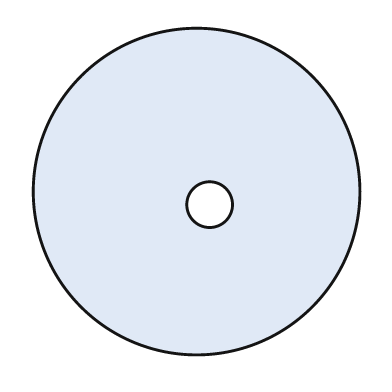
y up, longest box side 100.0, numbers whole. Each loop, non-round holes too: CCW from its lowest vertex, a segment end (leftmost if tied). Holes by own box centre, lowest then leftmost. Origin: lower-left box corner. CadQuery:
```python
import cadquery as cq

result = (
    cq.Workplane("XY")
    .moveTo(50.0, 50.0)
    .circle(50.0)
    .moveTo(54.0, 46.0)
    .circle(7.0)
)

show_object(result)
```